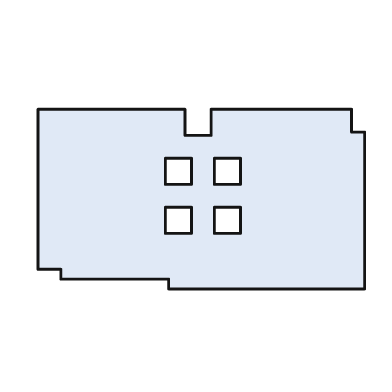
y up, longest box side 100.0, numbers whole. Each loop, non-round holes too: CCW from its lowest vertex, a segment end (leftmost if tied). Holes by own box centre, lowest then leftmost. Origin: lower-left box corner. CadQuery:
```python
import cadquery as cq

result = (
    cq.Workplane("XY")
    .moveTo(40.0, 0.0)
    .lineTo(100.0, 0.0)
    .lineTo(100.0, 48.0)
    .lineTo(96.0, 48.0)
    .lineTo(96.0, 55.0)
    .lineTo(53.0, 55.0)
    .lineTo(53.0, 47.0)
    .lineTo(45.0, 47.0)
    .lineTo(45.0, 55.0)
    .lineTo(0.0, 55.0)
    .lineTo(0.0, 6.0)
    .lineTo(7.0, 6.0)
    .lineTo(7.0, 3.0)
    .lineTo(40.0, 3.0)
    .close()
    .moveTo(39.0, 17.0)
    .lineTo(47.0, 17.0)
    .lineTo(47.0, 25.0)
    .lineTo(39.0, 25.0)
    .close()
    .moveTo(54.0, 17.0)
    .lineTo(62.0, 17.0)
    .lineTo(62.0, 25.0)
    .lineTo(54.0, 25.0)
    .close()
    .moveTo(39.0, 32.0)
    .lineTo(47.0, 32.0)
    .lineTo(47.0, 40.0)
    .lineTo(39.0, 40.0)
    .close()
    .moveTo(54.0, 32.0)
    .lineTo(62.0, 32.0)
    .lineTo(62.0, 40.0)
    .lineTo(54.0, 40.0)
    .close()
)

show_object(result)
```